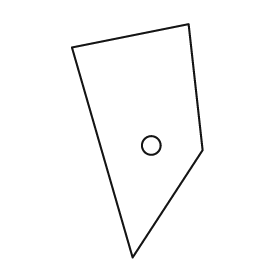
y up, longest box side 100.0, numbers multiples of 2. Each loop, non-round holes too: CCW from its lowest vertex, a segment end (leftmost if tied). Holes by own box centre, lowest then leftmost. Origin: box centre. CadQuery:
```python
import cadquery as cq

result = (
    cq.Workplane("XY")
    .moveTo(-2.0, -50.0)
    .lineTo(28.0, -4.0)
    .lineTo(22.0, 50.0)
    .lineTo(-28.0, 40.0)
    .close()
    .moveTo(6.0, -2.0)
    .circle(4.0)
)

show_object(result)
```